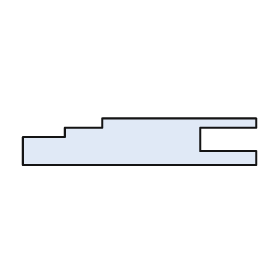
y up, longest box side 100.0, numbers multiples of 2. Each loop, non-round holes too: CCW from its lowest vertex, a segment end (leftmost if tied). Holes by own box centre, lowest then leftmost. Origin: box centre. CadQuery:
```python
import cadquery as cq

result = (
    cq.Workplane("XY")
    .moveTo(-50.0, -10.0)
    .lineTo(50.0, -10.0)
    .lineTo(50.0, -4.0)
    .lineTo(26.0, -4.0)
    .lineTo(26.0, 6.0)
    .lineTo(50.0, 6.0)
    .lineTo(50.0, 10.0)
    .lineTo(-16.0, 10.0)
    .lineTo(-16.0, 6.0)
    .lineTo(-32.0, 6.0)
    .lineTo(-32.0, 2.0)
    .lineTo(-50.0, 2.0)
    .close()
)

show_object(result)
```